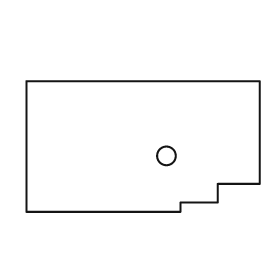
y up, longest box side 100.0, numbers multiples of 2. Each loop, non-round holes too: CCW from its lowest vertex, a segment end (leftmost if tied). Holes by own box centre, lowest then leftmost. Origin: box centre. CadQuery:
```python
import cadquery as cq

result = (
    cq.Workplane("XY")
    .moveTo(-50.0, -28.0)
    .lineTo(16.0, -28.0)
    .lineTo(16.0, -24.0)
    .lineTo(32.0, -24.0)
    .lineTo(32.0, -16.0)
    .lineTo(50.0, -16.0)
    .lineTo(50.0, 28.0)
    .lineTo(-50.0, 28.0)
    .close()
    .moveTo(10.0, -4.0)
    .circle(4.0)
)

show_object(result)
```